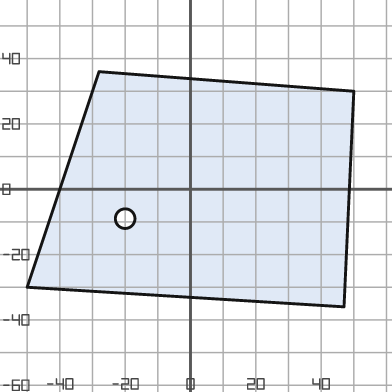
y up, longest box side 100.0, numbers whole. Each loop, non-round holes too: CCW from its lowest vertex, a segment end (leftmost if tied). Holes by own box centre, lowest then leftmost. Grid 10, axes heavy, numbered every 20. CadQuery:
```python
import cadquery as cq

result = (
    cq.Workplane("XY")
    .moveTo(47.0, -36.0)
    .lineTo(50.0, 30.0)
    .lineTo(-28.0, 36.0)
    .lineTo(-50.0, -30.0)
    .close()
    .moveTo(-20.0, -9.0)
    .circle(3.0)
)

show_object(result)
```